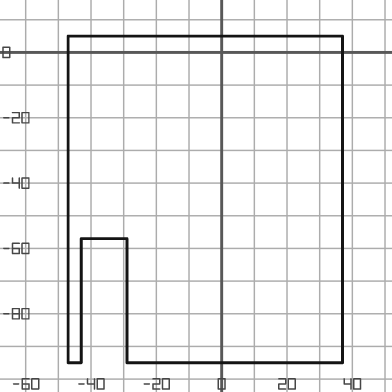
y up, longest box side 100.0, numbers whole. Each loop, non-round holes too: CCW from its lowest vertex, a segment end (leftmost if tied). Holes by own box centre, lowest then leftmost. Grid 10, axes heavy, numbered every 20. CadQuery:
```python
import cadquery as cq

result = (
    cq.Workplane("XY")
    .moveTo(-47.0, -95.0)
    .lineTo(-43.0, -95.0)
    .lineTo(-43.0, -57.0)
    .lineTo(-29.0, -57.0)
    .lineTo(-29.0, -95.0)
    .lineTo(37.0, -95.0)
    .lineTo(37.0, 5.0)
    .lineTo(-47.0, 5.0)
    .close()
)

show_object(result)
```